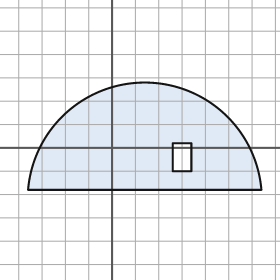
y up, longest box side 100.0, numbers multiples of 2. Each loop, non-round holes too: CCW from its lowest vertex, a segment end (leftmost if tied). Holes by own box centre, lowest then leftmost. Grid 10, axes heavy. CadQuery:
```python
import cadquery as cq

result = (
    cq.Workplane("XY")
    .moveTo(-36.0, -18.0)
    .lineTo(64.0, -18.0)
    .threePointArc((14.0, 28.0), (-36.0, -18.0))
    .close()
    .moveTo(26.0, -10.0)
    .lineTo(34.0, -10.0)
    .lineTo(34.0, 2.0)
    .lineTo(26.0, 2.0)
    .close()
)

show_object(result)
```